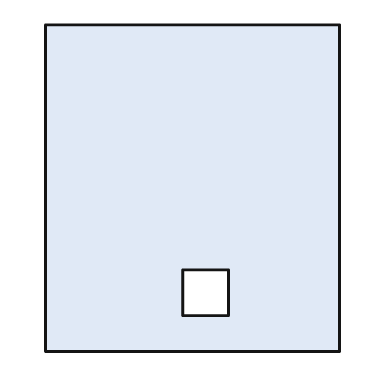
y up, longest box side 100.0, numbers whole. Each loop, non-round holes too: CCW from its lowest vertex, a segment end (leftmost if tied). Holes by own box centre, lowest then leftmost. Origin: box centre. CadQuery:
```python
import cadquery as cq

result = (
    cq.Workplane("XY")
    .moveTo(-45.0, -50.0)
    .lineTo(45.0, -50.0)
    .lineTo(45.0, 50.0)
    .lineTo(-45.0, 50.0)
    .close()
    .moveTo(-3.0, -39.0)
    .lineTo(11.0, -39.0)
    .lineTo(11.0, -25.0)
    .lineTo(-3.0, -25.0)
    .close()
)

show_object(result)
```